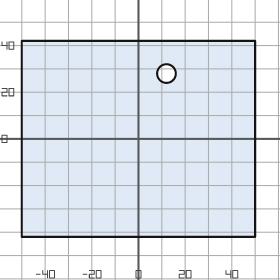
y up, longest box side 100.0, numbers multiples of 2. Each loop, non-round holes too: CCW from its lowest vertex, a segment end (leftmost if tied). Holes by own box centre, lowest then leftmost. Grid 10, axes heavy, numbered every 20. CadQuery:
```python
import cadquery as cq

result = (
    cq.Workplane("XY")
    .moveTo(-50.0, -42.0)
    .lineTo(50.0, -42.0)
    .lineTo(50.0, 42.0)
    .lineTo(-50.0, 42.0)
    .close()
    .moveTo(12.0, 28.0)
    .circle(4.0)
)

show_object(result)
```